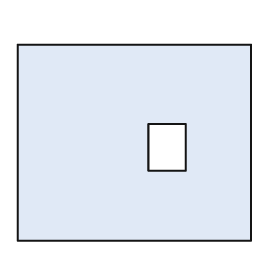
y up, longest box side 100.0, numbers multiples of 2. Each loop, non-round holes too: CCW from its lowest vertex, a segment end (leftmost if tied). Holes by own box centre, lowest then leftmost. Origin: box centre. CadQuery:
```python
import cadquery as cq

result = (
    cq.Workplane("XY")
    .moveTo(-50.0, -42.0)
    .lineTo(50.0, -42.0)
    .lineTo(50.0, 42.0)
    .lineTo(-50.0, 42.0)
    .close()
    .moveTo(6.0, -12.0)
    .lineTo(22.0, -12.0)
    .lineTo(22.0, 8.0)
    .lineTo(6.0, 8.0)
    .close()
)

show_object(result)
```